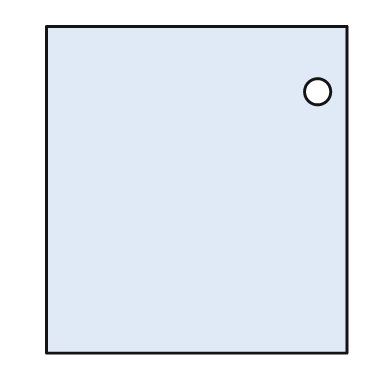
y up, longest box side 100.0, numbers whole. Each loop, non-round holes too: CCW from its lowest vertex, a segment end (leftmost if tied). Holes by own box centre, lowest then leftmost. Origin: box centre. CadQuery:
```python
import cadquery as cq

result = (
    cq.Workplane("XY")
    .moveTo(-46.0, -50.0)
    .lineTo(46.0, -50.0)
    .lineTo(46.0, 50.0)
    .lineTo(-46.0, 50.0)
    .close()
    .moveTo(37.0, 30.0)
    .circle(4.0)
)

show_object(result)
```